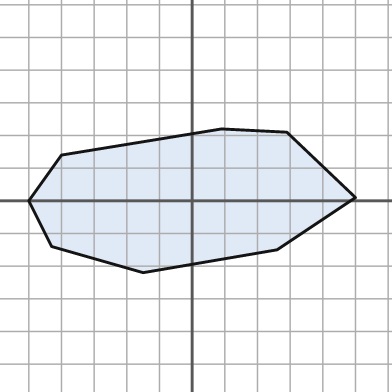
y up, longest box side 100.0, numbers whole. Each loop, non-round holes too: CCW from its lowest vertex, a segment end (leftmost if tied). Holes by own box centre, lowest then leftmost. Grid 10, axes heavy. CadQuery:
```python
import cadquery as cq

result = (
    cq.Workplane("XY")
    .moveTo(-15.0, -22.0)
    .lineTo(26.0, -15.0)
    .lineTo(50.0, 1.0)
    .lineTo(29.0, 21.0)
    .lineTo(9.0, 22.0)
    .lineTo(-40.0, 14.0)
    .lineTo(-50.0, 0.0)
    .lineTo(-43.0, -14.0)
    .close()
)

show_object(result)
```